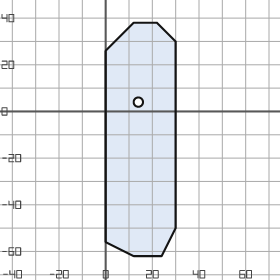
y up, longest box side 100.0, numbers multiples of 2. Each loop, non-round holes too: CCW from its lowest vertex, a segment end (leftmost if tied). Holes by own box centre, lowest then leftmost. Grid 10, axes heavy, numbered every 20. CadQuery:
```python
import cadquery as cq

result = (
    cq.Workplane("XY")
    .moveTo(12.0, -62.0)
    .lineTo(24.0, -62.0)
    .lineTo(30.0, -50.0)
    .lineTo(30.0, 30.0)
    .lineTo(22.0, 38.0)
    .lineTo(12.0, 38.0)
    .lineTo(0.0, 26.0)
    .lineTo(0.0, -56.0)
    .close()
    .moveTo(14.0, 4.0)
    .circle(2.0)
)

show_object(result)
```